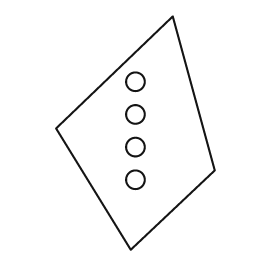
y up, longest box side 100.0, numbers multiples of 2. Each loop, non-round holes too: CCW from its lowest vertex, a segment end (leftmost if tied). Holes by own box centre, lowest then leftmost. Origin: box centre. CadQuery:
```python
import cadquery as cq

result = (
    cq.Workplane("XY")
    .moveTo(-2.0, -50.0)
    .lineTo(34.0, -16.0)
    .lineTo(16.0, 50.0)
    .lineTo(-34.0, 2.0)
    .close()
    .moveTo(0.0, -20.0)
    .circle(4.0)
    .moveTo(0.0, -6.0)
    .circle(4.0)
    .moveTo(0.0, 8.0)
    .circle(4.0)
    .moveTo(0.0, 22.0)
    .circle(4.0)
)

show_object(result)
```